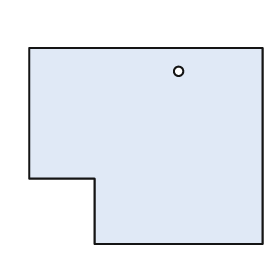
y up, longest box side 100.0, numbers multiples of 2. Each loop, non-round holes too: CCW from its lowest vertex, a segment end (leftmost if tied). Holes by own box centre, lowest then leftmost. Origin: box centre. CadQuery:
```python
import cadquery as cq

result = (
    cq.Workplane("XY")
    .moveTo(-22.0, -42.0)
    .lineTo(50.0, -42.0)
    .lineTo(50.0, 42.0)
    .lineTo(-50.0, 42.0)
    .lineTo(-50.0, -14.0)
    .lineTo(-22.0, -14.0)
    .close()
    .moveTo(14.0, 32.0)
    .circle(2.0)
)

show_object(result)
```